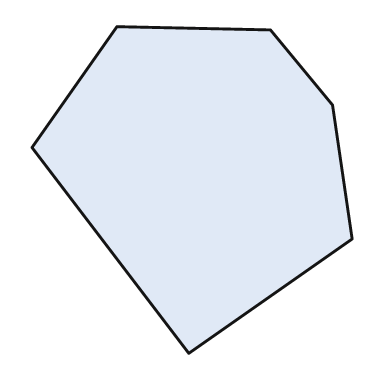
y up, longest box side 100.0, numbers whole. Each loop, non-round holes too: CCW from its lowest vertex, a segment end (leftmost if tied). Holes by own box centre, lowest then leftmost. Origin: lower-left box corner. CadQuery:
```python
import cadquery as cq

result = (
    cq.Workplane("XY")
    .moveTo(48.0, 0.0)
    .lineTo(98.0, 35.0)
    .lineTo(92.0, 76.0)
    .lineTo(73.0, 99.0)
    .lineTo(26.0, 100.0)
    .lineTo(0.0, 63.0)
    .close()
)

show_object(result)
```